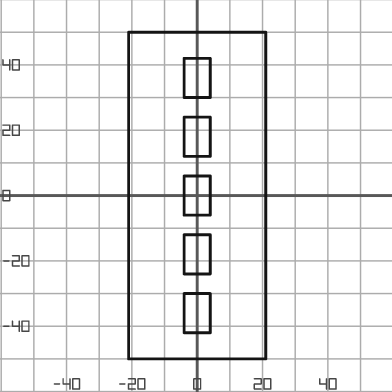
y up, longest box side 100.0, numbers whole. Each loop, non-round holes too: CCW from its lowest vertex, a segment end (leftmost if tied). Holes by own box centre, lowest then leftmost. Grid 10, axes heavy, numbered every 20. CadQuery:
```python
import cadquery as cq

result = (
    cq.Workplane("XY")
    .moveTo(-21.0, -50.0)
    .lineTo(21.0, -50.0)
    .lineTo(21.0, 50.0)
    .lineTo(-21.0, 50.0)
    .close()
    .moveTo(-4.0, -42.0)
    .lineTo(4.0, -42.0)
    .lineTo(4.0, -30.0)
    .lineTo(-4.0, -30.0)
    .close()
    .moveTo(-4.0, -24.0)
    .lineTo(4.0, -24.0)
    .lineTo(4.0, -12.0)
    .lineTo(-4.0, -12.0)
    .close()
    .moveTo(-4.0, -6.0)
    .lineTo(4.0, -6.0)
    .lineTo(4.0, 6.0)
    .lineTo(-4.0, 6.0)
    .close()
    .moveTo(-4.0, 12.0)
    .lineTo(4.0, 12.0)
    .lineTo(4.0, 24.0)
    .lineTo(-4.0, 24.0)
    .close()
    .moveTo(-4.0, 30.0)
    .lineTo(4.0, 30.0)
    .lineTo(4.0, 42.0)
    .lineTo(-4.0, 42.0)
    .close()
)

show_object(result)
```